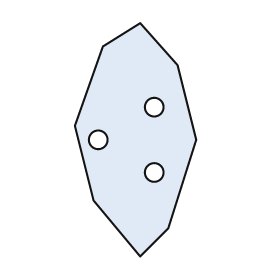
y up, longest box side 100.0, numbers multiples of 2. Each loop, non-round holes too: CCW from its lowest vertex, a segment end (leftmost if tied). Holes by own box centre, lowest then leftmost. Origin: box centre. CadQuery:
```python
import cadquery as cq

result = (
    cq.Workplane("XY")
    .moveTo(2.0, -50.0)
    .lineTo(14.0, -38.0)
    .lineTo(26.0, 0.0)
    .lineTo(18.0, 32.0)
    .lineTo(2.0, 50.0)
    .lineTo(-14.0, 40.0)
    .lineTo(-26.0, 6.0)
    .lineTo(-18.0, -26.0)
    .close()
    .moveTo(8.0, -14.0)
    .circle(4.0)
    .moveTo(-16.0, 0.0)
    .circle(4.0)
    .moveTo(8.0, 14.0)
    .circle(4.0)
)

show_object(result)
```